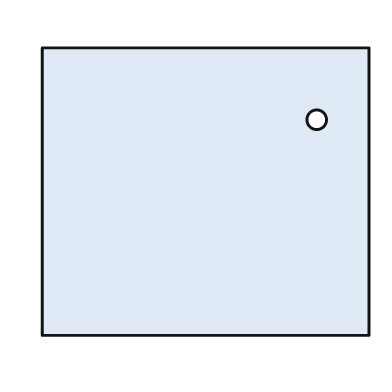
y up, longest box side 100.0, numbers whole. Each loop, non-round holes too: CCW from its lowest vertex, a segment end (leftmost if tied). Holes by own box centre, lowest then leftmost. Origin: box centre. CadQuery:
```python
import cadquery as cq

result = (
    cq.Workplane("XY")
    .moveTo(-50.0, -44.0)
    .lineTo(50.0, -44.0)
    .lineTo(50.0, 44.0)
    .lineTo(-50.0, 44.0)
    .close()
    .moveTo(34.0, 22.0)
    .circle(3.0)
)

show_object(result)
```